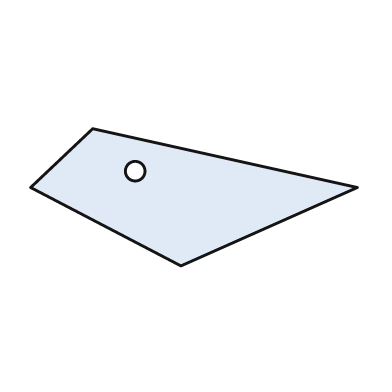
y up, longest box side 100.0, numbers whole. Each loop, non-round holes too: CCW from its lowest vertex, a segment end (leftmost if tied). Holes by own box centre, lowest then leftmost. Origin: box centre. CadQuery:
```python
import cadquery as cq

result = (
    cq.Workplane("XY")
    .moveTo(-4.0, -21.0)
    .lineTo(50.0, 3.0)
    .lineTo(-31.0, 21.0)
    .lineTo(-50.0, 3.0)
    .close()
    .moveTo(-18.0, 8.0)
    .circle(3.0)
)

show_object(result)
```